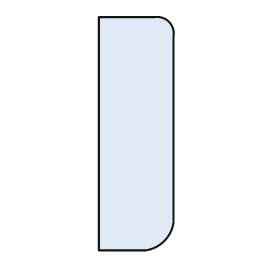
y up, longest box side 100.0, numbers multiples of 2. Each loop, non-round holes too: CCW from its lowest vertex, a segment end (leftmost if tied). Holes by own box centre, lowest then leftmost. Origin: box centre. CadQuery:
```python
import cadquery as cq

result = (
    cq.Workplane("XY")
    .moveTo(-16.0, -50.0)
    .lineTo(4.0, -50.0)
    .threePointArc((12.0, -46.0), (16.0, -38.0))
    .lineTo(16.0, 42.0)
    .threePointArc((14.0, 48.0), (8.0, 50.0))
    .lineTo(-16.0, 50.0)
    .close()
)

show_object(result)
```